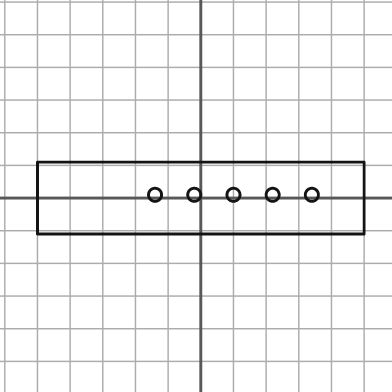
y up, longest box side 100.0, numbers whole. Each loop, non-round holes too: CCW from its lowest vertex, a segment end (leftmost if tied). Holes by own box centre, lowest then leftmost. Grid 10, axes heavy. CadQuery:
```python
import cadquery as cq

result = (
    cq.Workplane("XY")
    .moveTo(-50.0, -11.0)
    .lineTo(50.0, -11.0)
    .lineTo(50.0, 11.0)
    .lineTo(-50.0, 11.0)
    .close()
    .moveTo(-14.0, 1.0)
    .circle(2.0)
    .moveTo(-2.0, 1.0)
    .circle(2.0)
    .moveTo(10.0, 1.0)
    .circle(2.0)
    .moveTo(22.0, 1.0)
    .circle(2.0)
    .moveTo(34.0, 1.0)
    .circle(2.0)
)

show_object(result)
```